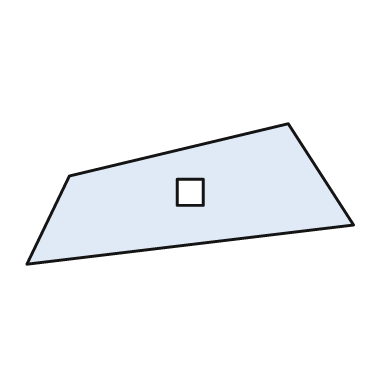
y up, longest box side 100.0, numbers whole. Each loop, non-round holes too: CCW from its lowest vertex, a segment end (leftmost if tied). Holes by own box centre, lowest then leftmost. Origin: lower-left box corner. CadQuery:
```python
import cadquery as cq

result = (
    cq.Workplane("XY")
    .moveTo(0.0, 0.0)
    .lineTo(100.0, 12.0)
    .lineTo(80.0, 43.0)
    .lineTo(13.0, 27.0)
    .close()
    .moveTo(46.0, 18.0)
    .lineTo(54.0, 18.0)
    .lineTo(54.0, 26.0)
    .lineTo(46.0, 26.0)
    .close()
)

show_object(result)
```